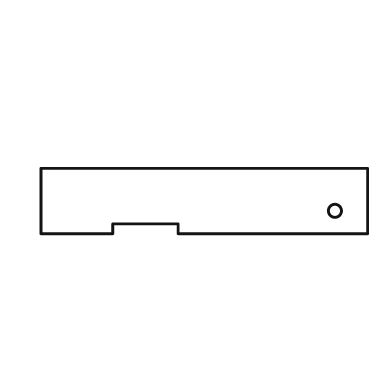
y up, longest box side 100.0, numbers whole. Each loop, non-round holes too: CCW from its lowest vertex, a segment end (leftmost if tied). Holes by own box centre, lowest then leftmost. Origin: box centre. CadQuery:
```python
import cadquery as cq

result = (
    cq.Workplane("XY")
    .moveTo(-50.0, -10.0)
    .lineTo(-28.0, -10.0)
    .lineTo(-28.0, -7.0)
    .lineTo(-8.0, -7.0)
    .lineTo(-8.0, -10.0)
    .lineTo(50.0, -10.0)
    .lineTo(50.0, 10.0)
    .lineTo(-50.0, 10.0)
    .close()
    .moveTo(40.0, -3.0)
    .circle(2.0)
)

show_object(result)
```